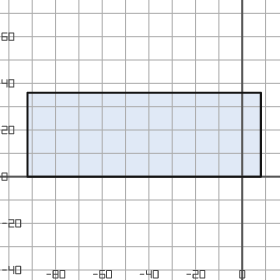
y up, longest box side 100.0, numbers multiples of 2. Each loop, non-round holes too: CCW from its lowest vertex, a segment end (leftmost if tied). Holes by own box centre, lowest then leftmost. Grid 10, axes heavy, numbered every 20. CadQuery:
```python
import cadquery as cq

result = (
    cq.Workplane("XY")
    .moveTo(-92.0, 0.0)
    .lineTo(8.0, 0.0)
    .lineTo(8.0, 36.0)
    .lineTo(-92.0, 36.0)
    .close()
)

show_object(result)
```